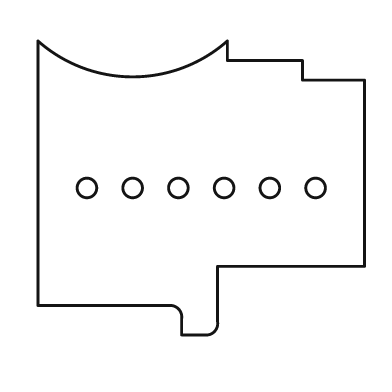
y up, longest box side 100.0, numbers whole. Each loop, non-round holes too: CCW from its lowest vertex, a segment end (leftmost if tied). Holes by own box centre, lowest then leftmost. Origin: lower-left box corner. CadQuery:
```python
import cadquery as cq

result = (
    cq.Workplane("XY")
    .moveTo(44.0, 0.0)
    .lineTo(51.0, 0.0)
    .threePointArc((54.0, 1.0), (55.0, 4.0))
    .lineTo(55.0, 21.0)
    .lineTo(100.0, 21.0)
    .lineTo(100.0, 78.0)
    .lineTo(81.0, 78.0)
    .lineTo(81.0, 84.0)
    .lineTo(58.0, 84.0)
    .lineTo(58.0, 90.0)
    .threePointArc((29.0, 79.0), (0.0, 90.0))
    .lineTo(0.0, 9.0)
    .lineTo(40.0, 9.0)
    .threePointArc((43.0, 8.0), (44.0, 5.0))
    .close()
    .moveTo(15.0, 45.0)
    .circle(3.0)
    .moveTo(29.0, 45.0)
    .circle(3.0)
    .moveTo(43.0, 45.0)
    .circle(3.0)
    .moveTo(57.0, 45.0)
    .circle(3.0)
    .moveTo(71.0, 45.0)
    .circle(3.0)
    .moveTo(85.0, 45.0)
    .circle(3.0)
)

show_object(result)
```